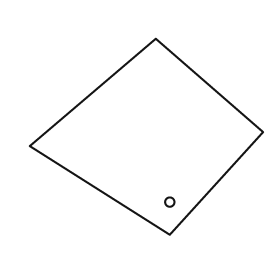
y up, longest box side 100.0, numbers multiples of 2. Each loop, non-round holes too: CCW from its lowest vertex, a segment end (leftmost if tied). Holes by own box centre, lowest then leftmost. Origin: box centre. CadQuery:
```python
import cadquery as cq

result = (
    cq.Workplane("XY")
    .moveTo(10.0, -42.0)
    .lineTo(50.0, 2.0)
    .lineTo(4.0, 42.0)
    .lineTo(-50.0, -4.0)
    .close()
    .moveTo(10.0, -28.0)
    .circle(2.0)
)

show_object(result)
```